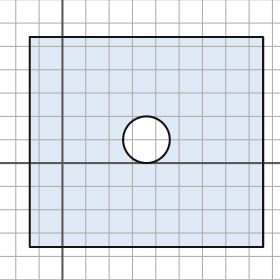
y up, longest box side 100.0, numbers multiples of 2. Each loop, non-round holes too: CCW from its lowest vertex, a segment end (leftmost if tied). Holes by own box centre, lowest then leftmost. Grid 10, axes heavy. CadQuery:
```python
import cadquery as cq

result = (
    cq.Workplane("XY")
    .moveTo(-14.0, -36.0)
    .lineTo(86.0, -36.0)
    .lineTo(86.0, 54.0)
    .lineTo(-14.0, 54.0)
    .close()
    .moveTo(36.0, 10.0)
    .circle(10.0)
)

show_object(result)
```